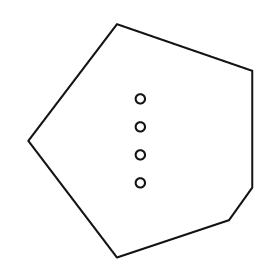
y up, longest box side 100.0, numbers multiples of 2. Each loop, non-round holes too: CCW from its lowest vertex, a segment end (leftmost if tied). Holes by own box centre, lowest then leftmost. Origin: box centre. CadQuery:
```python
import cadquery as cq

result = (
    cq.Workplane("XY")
    .moveTo(-10.0, -50.0)
    .lineTo(38.0, -34.0)
    .lineTo(48.0, -20.0)
    .lineTo(48.0, 30.0)
    .lineTo(-10.0, 50.0)
    .lineTo(-48.0, 0.0)
    .close()
    .moveTo(0.0, -18.0)
    .circle(2.0)
    .moveTo(0.0, -6.0)
    .circle(2.0)
    .moveTo(0.0, 6.0)
    .circle(2.0)
    .moveTo(0.0, 18.0)
    .circle(2.0)
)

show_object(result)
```